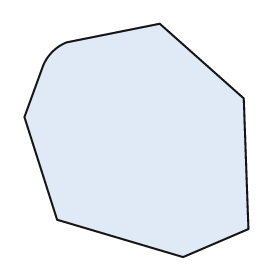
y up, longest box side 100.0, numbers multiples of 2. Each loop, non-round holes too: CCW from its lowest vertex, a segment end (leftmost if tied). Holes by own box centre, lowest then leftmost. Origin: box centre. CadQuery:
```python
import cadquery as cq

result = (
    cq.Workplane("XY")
    .moveTo(20.0, -50.0)
    .lineTo(48.0, -38.0)
    .lineTo(46.0, 18.0)
    .lineTo(10.0, 50.0)
    .lineTo(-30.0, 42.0)
    .threePointArc((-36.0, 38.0), (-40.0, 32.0))
    .lineTo(-48.0, 10.0)
    .lineTo(-34.0, -34.0)
    .close()
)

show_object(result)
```